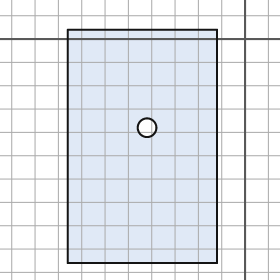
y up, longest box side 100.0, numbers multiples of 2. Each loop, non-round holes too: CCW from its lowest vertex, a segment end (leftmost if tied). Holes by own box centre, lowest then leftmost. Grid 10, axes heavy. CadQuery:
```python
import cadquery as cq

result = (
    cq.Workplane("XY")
    .moveTo(-76.0, -96.0)
    .lineTo(-12.0, -96.0)
    .lineTo(-12.0, 4.0)
    .lineTo(-76.0, 4.0)
    .close()
    .moveTo(-42.0, -38.0)
    .circle(4.0)
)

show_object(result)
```